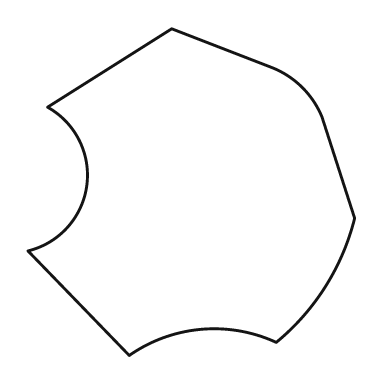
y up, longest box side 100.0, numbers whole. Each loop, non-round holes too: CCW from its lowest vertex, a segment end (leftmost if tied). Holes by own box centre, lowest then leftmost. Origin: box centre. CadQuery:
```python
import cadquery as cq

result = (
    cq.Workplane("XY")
    .moveTo(-19.0, -50.0)
    .threePointArc((3.0, -42.0), (26.0, -46.0))
    .threePointArc((41.0, -29.0), (50.0, -8.0))
    .lineTo(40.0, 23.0)
    .threePointArc((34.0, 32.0), (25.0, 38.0))
    .lineTo(-6.0, 50.0)
    .lineTo(-44.0, 26.0)
    .threePointArc((-32.0, 2.0), (-50.0, -18.0))
    .close()
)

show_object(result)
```